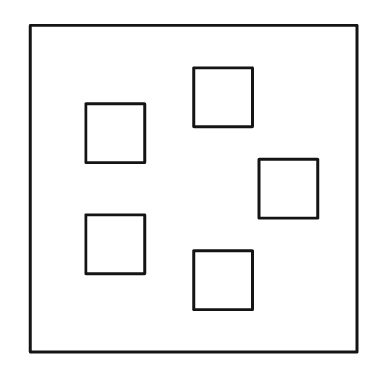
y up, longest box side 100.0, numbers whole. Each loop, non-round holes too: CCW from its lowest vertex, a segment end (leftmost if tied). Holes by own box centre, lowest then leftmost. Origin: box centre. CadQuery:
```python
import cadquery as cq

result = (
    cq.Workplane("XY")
    .moveTo(-50.0, -50.0)
    .lineTo(50.0, -50.0)
    .lineTo(50.0, 50.0)
    .lineTo(-50.0, 50.0)
    .close()
    .moveTo(0.0, -37.0)
    .lineTo(18.0, -37.0)
    .lineTo(18.0, -19.0)
    .lineTo(0.0, -19.0)
    .close()
    .moveTo(-33.0, -26.0)
    .lineTo(-15.0, -26.0)
    .lineTo(-15.0, -8.0)
    .lineTo(-33.0, -8.0)
    .close()
    .moveTo(20.0, -9.0)
    .lineTo(38.0, -9.0)
    .lineTo(38.0, 9.0)
    .lineTo(20.0, 9.0)
    .close()
    .moveTo(-33.0, 8.0)
    .lineTo(-15.0, 8.0)
    .lineTo(-15.0, 26.0)
    .lineTo(-33.0, 26.0)
    .close()
    .moveTo(0.0, 19.0)
    .lineTo(18.0, 19.0)
    .lineTo(18.0, 37.0)
    .lineTo(0.0, 37.0)
    .close()
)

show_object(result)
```